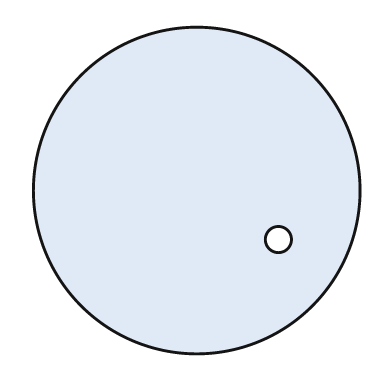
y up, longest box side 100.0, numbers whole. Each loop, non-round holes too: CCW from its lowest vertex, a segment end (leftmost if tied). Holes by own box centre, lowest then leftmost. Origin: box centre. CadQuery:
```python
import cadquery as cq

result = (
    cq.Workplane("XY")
    .moveTo(0.0, 0.0)
    .circle(50.0)
    .moveTo(25.0, -15.0)
    .circle(4.0)
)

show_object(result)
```